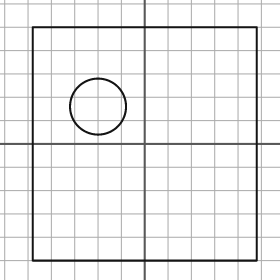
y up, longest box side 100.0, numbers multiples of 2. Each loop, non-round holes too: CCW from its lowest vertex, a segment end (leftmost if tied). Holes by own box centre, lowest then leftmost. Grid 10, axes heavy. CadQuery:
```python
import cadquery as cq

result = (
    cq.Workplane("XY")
    .moveTo(-48.0, -50.0)
    .lineTo(48.0, -50.0)
    .lineTo(48.0, 50.0)
    .lineTo(-48.0, 50.0)
    .close()
    .moveTo(-20.0, 16.0)
    .circle(12.0)
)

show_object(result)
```